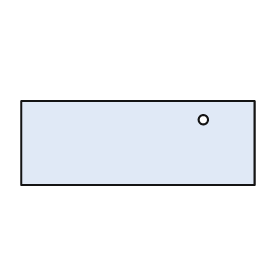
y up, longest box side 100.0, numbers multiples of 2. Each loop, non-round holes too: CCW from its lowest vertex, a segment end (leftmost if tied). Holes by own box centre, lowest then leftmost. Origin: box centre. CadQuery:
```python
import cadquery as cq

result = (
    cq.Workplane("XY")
    .moveTo(-50.0, -18.0)
    .lineTo(50.0, -18.0)
    .lineTo(50.0, 18.0)
    .lineTo(-50.0, 18.0)
    .close()
    .moveTo(28.0, 10.0)
    .circle(2.0)
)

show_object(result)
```